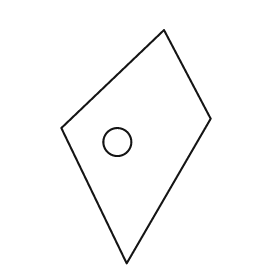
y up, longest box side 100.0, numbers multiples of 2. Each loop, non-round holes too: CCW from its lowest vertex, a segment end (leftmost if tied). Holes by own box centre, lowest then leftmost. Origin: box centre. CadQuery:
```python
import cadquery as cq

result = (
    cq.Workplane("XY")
    .moveTo(-4.0, -50.0)
    .lineTo(32.0, 12.0)
    .lineTo(12.0, 50.0)
    .lineTo(-32.0, 8.0)
    .close()
    .moveTo(-8.0, 2.0)
    .circle(6.0)
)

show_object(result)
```